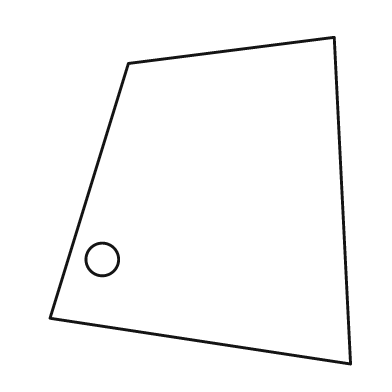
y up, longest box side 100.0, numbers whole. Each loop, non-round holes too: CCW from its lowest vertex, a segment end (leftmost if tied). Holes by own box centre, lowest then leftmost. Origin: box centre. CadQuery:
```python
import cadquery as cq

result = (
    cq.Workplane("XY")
    .moveTo(46.0, -50.0)
    .lineTo(41.0, 50.0)
    .lineTo(-22.0, 42.0)
    .lineTo(-46.0, -36.0)
    .close()
    .moveTo(-30.0, -18.0)
    .circle(5.0)
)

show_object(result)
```